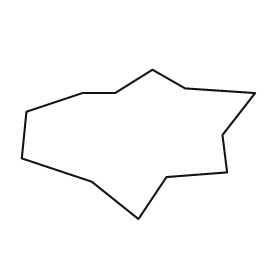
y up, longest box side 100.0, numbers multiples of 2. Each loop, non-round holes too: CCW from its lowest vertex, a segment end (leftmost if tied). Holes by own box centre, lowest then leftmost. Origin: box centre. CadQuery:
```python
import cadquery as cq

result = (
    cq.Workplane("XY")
    .moveTo(0.0, -32.0)
    .lineTo(12.0, -14.0)
    .lineTo(38.0, -12.0)
    .lineTo(36.0, 4.0)
    .lineTo(50.0, 22.0)
    .lineTo(20.0, 24.0)
    .lineTo(6.0, 32.0)
    .lineTo(-10.0, 22.0)
    .lineTo(-24.0, 22.0)
    .lineTo(-48.0, 14.0)
    .lineTo(-50.0, -6.0)
    .lineTo(-20.0, -16.0)
    .close()
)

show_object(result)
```